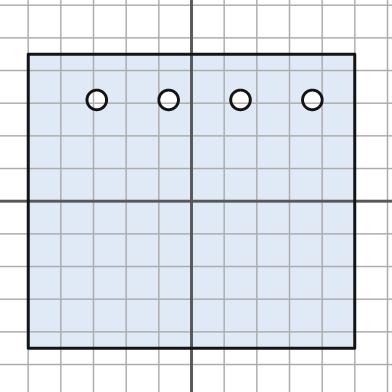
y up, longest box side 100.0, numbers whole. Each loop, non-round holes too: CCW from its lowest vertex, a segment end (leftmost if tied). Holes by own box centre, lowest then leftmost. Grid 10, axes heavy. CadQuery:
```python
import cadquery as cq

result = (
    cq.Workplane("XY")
    .moveTo(-50.0, -45.0)
    .lineTo(50.0, -45.0)
    .lineTo(50.0, 45.0)
    .lineTo(-50.0, 45.0)
    .close()
    .moveTo(-29.0, 31.0)
    .circle(3.0)
    .moveTo(-7.0, 31.0)
    .circle(3.0)
    .moveTo(15.0, 31.0)
    .circle(3.0)
    .moveTo(37.0, 31.0)
    .circle(3.0)
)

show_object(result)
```